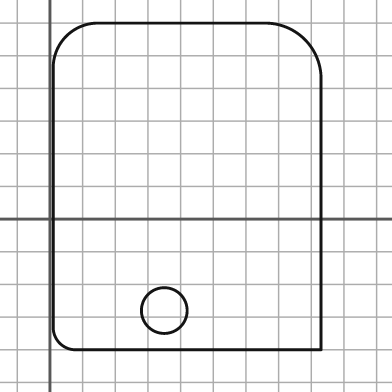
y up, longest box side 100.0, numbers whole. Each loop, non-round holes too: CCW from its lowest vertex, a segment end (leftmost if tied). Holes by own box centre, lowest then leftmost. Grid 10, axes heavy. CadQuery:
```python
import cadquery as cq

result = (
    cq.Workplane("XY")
    .moveTo(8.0, -40.0)
    .lineTo(83.0, -40.0)
    .lineTo(83.0, 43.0)
    .threePointArc((78.0, 55.0), (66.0, 60.0))
    .lineTo(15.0, 60.0)
    .threePointArc((5.0, 56.0), (1.0, 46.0))
    .lineTo(1.0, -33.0)
    .threePointArc((3.0, -38.0), (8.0, -40.0))
    .close()
    .moveTo(35.0, -28.0)
    .circle(7.0)
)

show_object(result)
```